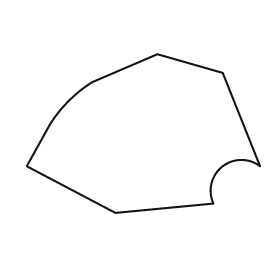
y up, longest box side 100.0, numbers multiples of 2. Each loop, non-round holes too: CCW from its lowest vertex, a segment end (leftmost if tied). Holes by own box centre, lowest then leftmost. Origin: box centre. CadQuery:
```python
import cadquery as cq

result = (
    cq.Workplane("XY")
    .moveTo(-12.0, -34.0)
    .lineTo(30.0, -30.0)
    .threePointArc((34.0, -14.0), (50.0, -14.0))
    .lineTo(34.0, 26.0)
    .lineTo(6.0, 34.0)
    .lineTo(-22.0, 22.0)
    .threePointArc((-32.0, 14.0), (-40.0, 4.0))
    .lineTo(-50.0, -14.0)
    .close()
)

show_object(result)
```